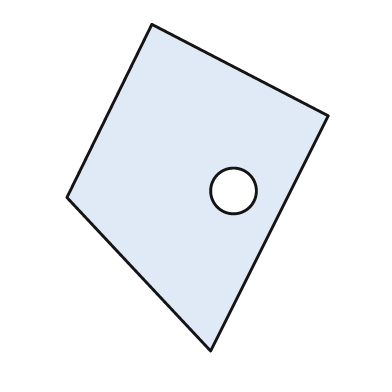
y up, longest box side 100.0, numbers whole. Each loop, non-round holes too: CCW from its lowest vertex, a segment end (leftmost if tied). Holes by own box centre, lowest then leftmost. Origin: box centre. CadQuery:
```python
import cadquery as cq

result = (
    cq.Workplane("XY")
    .moveTo(4.0, -50.0)
    .lineTo(40.0, 22.0)
    .lineTo(-14.0, 50.0)
    .lineTo(-40.0, -3.0)
    .close()
    .moveTo(11.0, -1.0)
    .circle(7.0)
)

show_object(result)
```